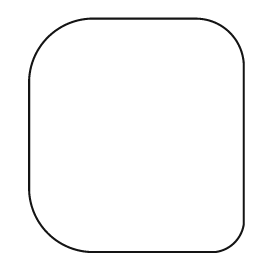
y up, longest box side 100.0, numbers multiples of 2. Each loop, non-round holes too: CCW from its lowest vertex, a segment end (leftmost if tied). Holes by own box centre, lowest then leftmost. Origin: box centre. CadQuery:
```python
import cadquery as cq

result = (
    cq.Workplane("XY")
    .moveTo(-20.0, -50.0)
    .lineTo(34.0, -50.0)
    .threePointArc((42.0, -46.0), (46.0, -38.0))
    .lineTo(46.0, 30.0)
    .threePointArc((40.0, 44.0), (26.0, 50.0))
    .lineTo(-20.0, 50.0)
    .threePointArc((-38.0, 42.0), (-46.0, 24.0))
    .lineTo(-46.0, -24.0)
    .threePointArc((-38.0, -42.0), (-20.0, -50.0))
    .close()
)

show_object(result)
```